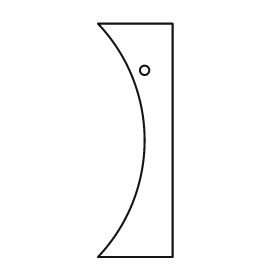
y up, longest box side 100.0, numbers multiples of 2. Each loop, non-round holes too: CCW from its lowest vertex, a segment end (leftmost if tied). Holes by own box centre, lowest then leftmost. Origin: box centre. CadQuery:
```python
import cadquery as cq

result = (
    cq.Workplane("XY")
    .moveTo(-16.0, -50.0)
    .lineTo(16.0, -50.0)
    .lineTo(16.0, 50.0)
    .lineTo(-16.0, 50.0)
    .threePointArc((4.0, 0.0), (-16.0, -50.0))
    .close()
    .moveTo(4.0, 30.0)
    .circle(2.0)
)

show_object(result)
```